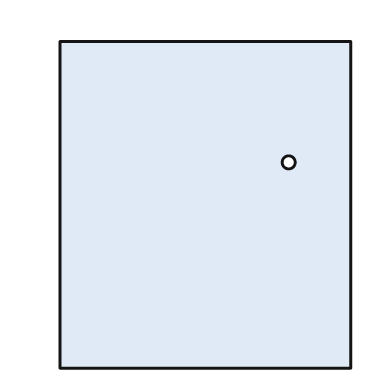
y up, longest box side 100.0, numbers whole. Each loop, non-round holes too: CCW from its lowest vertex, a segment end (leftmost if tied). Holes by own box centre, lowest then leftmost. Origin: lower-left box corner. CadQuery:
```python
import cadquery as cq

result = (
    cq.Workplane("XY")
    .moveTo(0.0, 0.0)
    .lineTo(89.0, 0.0)
    .lineTo(89.0, 100.0)
    .lineTo(0.0, 100.0)
    .close()
    .moveTo(70.0, 63.0)
    .circle(2.0)
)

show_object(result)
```